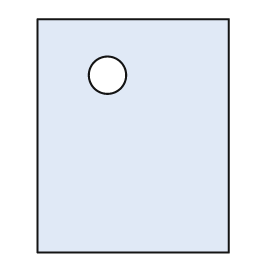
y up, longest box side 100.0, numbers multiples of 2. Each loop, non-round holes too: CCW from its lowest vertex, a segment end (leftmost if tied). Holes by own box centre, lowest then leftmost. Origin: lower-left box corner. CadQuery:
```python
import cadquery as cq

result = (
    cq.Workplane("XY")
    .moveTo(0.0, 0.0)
    .lineTo(82.0, 0.0)
    .lineTo(82.0, 100.0)
    .lineTo(0.0, 100.0)
    .close()
    .moveTo(30.0, 76.0)
    .circle(8.0)
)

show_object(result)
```